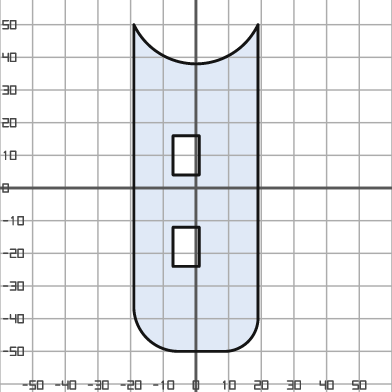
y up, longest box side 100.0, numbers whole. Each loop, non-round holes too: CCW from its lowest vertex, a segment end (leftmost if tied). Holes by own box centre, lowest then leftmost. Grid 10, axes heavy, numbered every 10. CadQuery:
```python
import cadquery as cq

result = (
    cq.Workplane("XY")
    .moveTo(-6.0, -50.0)
    .lineTo(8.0, -50.0)
    .threePointArc((16.0, -47.0), (19.0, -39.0))
    .lineTo(19.0, 50.0)
    .threePointArc((0.0, 38.0), (-19.0, 50.0))
    .lineTo(-19.0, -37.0)
    .threePointArc((-15.0, -46.0), (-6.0, -50.0))
    .close()
    .moveTo(-7.0, -24.0)
    .lineTo(1.0, -24.0)
    .lineTo(1.0, -12.0)
    .lineTo(-7.0, -12.0)
    .close()
    .moveTo(-7.0, 4.0)
    .lineTo(1.0, 4.0)
    .lineTo(1.0, 16.0)
    .lineTo(-7.0, 16.0)
    .close()
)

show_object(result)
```